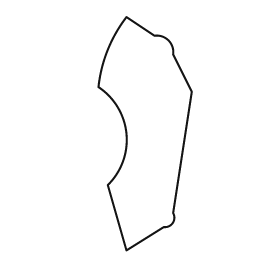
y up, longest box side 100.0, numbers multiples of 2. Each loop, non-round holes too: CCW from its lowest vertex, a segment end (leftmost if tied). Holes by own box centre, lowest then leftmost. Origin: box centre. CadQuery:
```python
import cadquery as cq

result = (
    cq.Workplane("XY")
    .moveTo(-8.0, -50.0)
    .lineTo(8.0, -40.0)
    .threePointArc((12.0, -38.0), (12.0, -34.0))
    .lineTo(20.0, 18.0)
    .lineTo(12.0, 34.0)
    .threePointArc((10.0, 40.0), (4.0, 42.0))
    .lineTo(-8.0, 50.0)
    .threePointArc((-16.0, 36.0), (-20.0, 20.0))
    .threePointArc((-8.0, 0.0), (-16.0, -22.0))
    .close()
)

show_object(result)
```